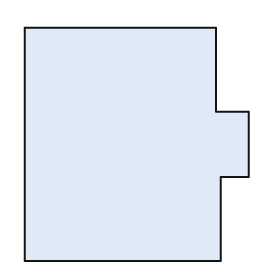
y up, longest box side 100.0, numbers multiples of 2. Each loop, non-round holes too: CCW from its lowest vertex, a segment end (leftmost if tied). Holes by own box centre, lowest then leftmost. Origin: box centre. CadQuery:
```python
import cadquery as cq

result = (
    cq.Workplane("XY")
    .moveTo(-48.0, -50.0)
    .lineTo(36.0, -50.0)
    .lineTo(36.0, -14.0)
    .lineTo(48.0, -14.0)
    .lineTo(48.0, 14.0)
    .lineTo(34.0, 14.0)
    .lineTo(34.0, 50.0)
    .lineTo(-48.0, 50.0)
    .close()
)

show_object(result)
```